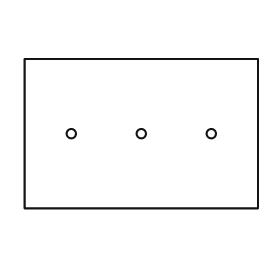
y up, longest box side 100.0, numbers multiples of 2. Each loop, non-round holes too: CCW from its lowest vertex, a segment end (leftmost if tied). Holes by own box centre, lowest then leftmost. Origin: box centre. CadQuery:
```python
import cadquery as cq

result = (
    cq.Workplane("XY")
    .moveTo(-50.0, -32.0)
    .lineTo(50.0, -32.0)
    .lineTo(50.0, 32.0)
    .lineTo(-50.0, 32.0)
    .close()
    .moveTo(-30.0, 0.0)
    .circle(2.0)
    .moveTo(0.0, 0.0)
    .circle(2.0)
    .moveTo(30.0, 0.0)
    .circle(2.0)
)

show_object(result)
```